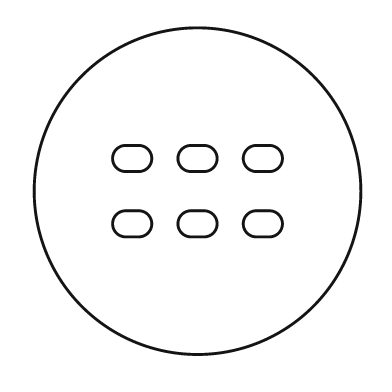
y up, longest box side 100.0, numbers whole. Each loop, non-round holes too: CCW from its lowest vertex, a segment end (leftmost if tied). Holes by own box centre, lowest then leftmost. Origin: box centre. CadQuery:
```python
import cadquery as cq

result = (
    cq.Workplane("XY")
    .moveTo(0.0, 0.0)
    .circle(50.0)
    .moveTo(-22.0, -14.0)
    .lineTo(-18.0, -14.0)
    .threePointArc((-14.0, -10.0), (-18.0, -6.0))
    .lineTo(-22.0, -6.0)
    .threePointArc((-26.0, -10.0), (-22.0, -14.0))
    .close()
    .moveTo(-2.0, -14.0)
    .lineTo(2.0, -14.0)
    .threePointArc((6.0, -10.0), (2.0, -6.0))
    .lineTo(-2.0, -6.0)
    .threePointArc((-6.0, -10.0), (-2.0, -14.0))
    .close()
    .moveTo(18.0, -14.0)
    .lineTo(22.0, -14.0)
    .threePointArc((26.0, -10.0), (22.0, -6.0))
    .lineTo(18.0, -6.0)
    .threePointArc((14.0, -10.0), (18.0, -14.0))
    .close()
    .moveTo(-22.0, 6.0)
    .lineTo(-18.0, 6.0)
    .threePointArc((-14.0, 10.0), (-18.0, 14.0))
    .lineTo(-22.0, 14.0)
    .threePointArc((-26.0, 10.0), (-22.0, 6.0))
    .close()
    .moveTo(-2.0, 6.0)
    .lineTo(2.0, 6.0)
    .threePointArc((6.0, 10.0), (2.0, 14.0))
    .lineTo(-2.0, 14.0)
    .threePointArc((-6.0, 10.0), (-2.0, 6.0))
    .close()
    .moveTo(18.0, 6.0)
    .lineTo(22.0, 6.0)
    .threePointArc((26.0, 10.0), (22.0, 14.0))
    .lineTo(18.0, 14.0)
    .threePointArc((14.0, 10.0), (18.0, 6.0))
    .close()
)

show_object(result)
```